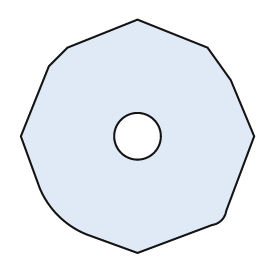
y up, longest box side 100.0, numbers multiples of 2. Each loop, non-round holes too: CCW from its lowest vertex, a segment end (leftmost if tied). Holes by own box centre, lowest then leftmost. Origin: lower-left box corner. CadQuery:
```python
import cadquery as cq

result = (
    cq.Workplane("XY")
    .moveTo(50.0, 0.0)
    .lineTo(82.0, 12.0)
    .threePointArc((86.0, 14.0), (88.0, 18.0))
    .lineTo(100.0, 50.0)
    .lineTo(90.0, 74.0)
    .lineTo(80.0, 88.0)
    .lineTo(50.0, 100.0)
    .lineTo(20.0, 88.0)
    .lineTo(12.0, 80.0)
    .lineTo(0.0, 50.0)
    .lineTo(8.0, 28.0)
    .threePointArc((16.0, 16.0), (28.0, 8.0))
    .close()
    .moveTo(50.0, 50.0)
    .circle(10.0)
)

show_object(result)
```